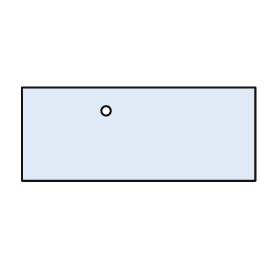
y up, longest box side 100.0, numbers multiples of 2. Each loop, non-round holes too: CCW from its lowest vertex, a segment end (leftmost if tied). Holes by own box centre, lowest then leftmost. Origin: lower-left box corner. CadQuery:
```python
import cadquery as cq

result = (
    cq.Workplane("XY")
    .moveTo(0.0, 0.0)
    .lineTo(100.0, 0.0)
    .lineTo(100.0, 40.0)
    .lineTo(0.0, 40.0)
    .close()
    .moveTo(36.0, 30.0)
    .circle(2.0)
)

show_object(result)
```